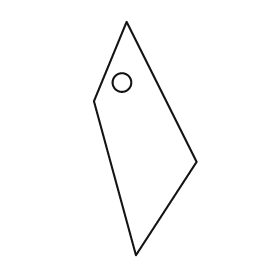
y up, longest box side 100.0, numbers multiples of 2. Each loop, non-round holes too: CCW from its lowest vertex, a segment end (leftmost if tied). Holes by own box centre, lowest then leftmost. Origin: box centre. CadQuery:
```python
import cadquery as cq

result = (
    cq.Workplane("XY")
    .moveTo(-4.0, -50.0)
    .lineTo(22.0, -10.0)
    .lineTo(-8.0, 50.0)
    .lineTo(-22.0, 16.0)
    .close()
    .moveTo(-10.0, 24.0)
    .circle(4.0)
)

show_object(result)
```